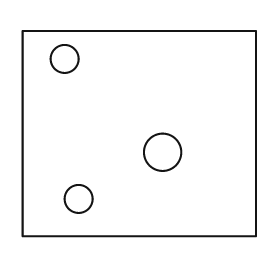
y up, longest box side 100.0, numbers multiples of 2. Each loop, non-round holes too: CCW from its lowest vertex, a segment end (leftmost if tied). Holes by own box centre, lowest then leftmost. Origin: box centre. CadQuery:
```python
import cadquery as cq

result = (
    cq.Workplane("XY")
    .moveTo(-50.0, -44.0)
    .lineTo(50.0, -44.0)
    .lineTo(50.0, 44.0)
    .lineTo(-50.0, 44.0)
    .close()
    .moveTo(-26.0, -28.0)
    .circle(6.0)
    .moveTo(10.0, -8.0)
    .circle(8.0)
    .moveTo(-32.0, 32.0)
    .circle(6.0)
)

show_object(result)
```